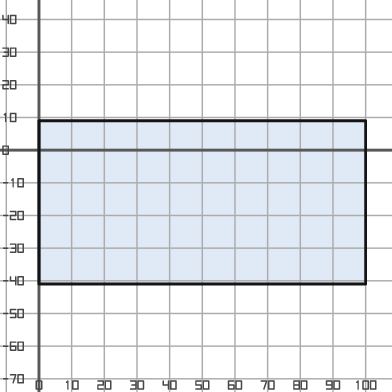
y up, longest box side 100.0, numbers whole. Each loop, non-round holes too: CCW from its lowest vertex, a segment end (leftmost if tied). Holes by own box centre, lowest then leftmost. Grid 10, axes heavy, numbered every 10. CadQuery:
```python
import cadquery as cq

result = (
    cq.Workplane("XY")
    .moveTo(0.0, -41.0)
    .lineTo(100.0, -41.0)
    .lineTo(100.0, 9.0)
    .lineTo(0.0, 9.0)
    .close()
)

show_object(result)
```